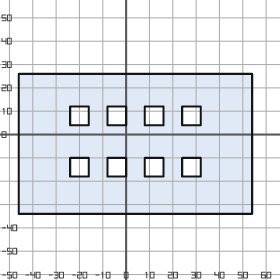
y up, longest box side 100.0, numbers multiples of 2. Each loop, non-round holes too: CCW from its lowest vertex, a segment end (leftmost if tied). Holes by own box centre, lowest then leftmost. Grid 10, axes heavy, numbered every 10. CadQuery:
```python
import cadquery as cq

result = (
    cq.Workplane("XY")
    .moveTo(-46.0, -34.0)
    .lineTo(54.0, -34.0)
    .lineTo(54.0, 26.0)
    .lineTo(-46.0, 26.0)
    .close()
    .moveTo(-24.0, -18.0)
    .lineTo(-16.0, -18.0)
    .lineTo(-16.0, -10.0)
    .lineTo(-24.0, -10.0)
    .close()
    .moveTo(-8.0, -18.0)
    .lineTo(0.0, -18.0)
    .lineTo(0.0, -10.0)
    .lineTo(-8.0, -10.0)
    .close()
    .moveTo(8.0, -18.0)
    .lineTo(16.0, -18.0)
    .lineTo(16.0, -10.0)
    .lineTo(8.0, -10.0)
    .close()
    .moveTo(24.0, -18.0)
    .lineTo(32.0, -18.0)
    .lineTo(32.0, -10.0)
    .lineTo(24.0, -10.0)
    .close()
    .moveTo(-24.0, 4.0)
    .lineTo(-16.0, 4.0)
    .lineTo(-16.0, 12.0)
    .lineTo(-24.0, 12.0)
    .close()
    .moveTo(-8.0, 4.0)
    .lineTo(0.0, 4.0)
    .lineTo(0.0, 12.0)
    .lineTo(-8.0, 12.0)
    .close()
    .moveTo(8.0, 4.0)
    .lineTo(16.0, 4.0)
    .lineTo(16.0, 12.0)
    .lineTo(8.0, 12.0)
    .close()
    .moveTo(24.0, 4.0)
    .lineTo(32.0, 4.0)
    .lineTo(32.0, 12.0)
    .lineTo(24.0, 12.0)
    .close()
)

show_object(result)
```